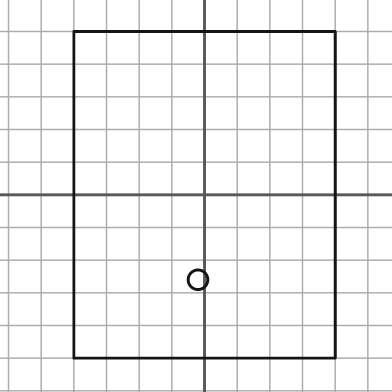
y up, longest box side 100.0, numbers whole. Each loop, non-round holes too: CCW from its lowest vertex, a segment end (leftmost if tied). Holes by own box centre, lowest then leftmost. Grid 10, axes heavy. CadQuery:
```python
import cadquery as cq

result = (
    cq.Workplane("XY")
    .moveTo(-40.0, -50.0)
    .lineTo(40.0, -50.0)
    .lineTo(40.0, 50.0)
    .lineTo(-40.0, 50.0)
    .close()
    .moveTo(-2.0, -26.0)
    .circle(3.0)
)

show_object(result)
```